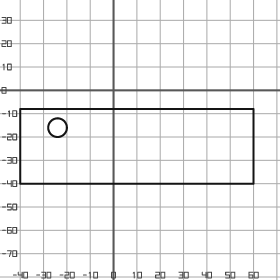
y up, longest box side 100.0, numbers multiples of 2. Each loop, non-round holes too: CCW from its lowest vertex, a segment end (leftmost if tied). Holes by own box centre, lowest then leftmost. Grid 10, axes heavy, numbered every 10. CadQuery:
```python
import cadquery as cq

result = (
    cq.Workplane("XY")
    .moveTo(-40.0, -40.0)
    .lineTo(60.0, -40.0)
    .lineTo(60.0, -8.0)
    .lineTo(-40.0, -8.0)
    .close()
    .moveTo(-24.0, -16.0)
    .circle(4.0)
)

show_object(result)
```